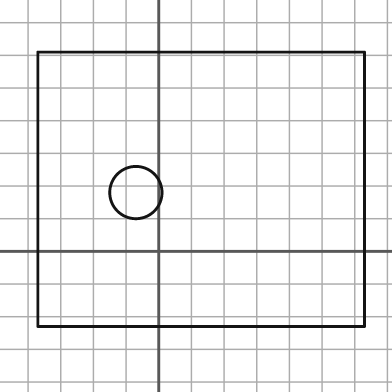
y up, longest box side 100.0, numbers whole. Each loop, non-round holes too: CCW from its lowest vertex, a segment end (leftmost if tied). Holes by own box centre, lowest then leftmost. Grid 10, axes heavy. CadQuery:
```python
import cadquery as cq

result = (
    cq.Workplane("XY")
    .moveTo(-37.0, -23.0)
    .lineTo(63.0, -23.0)
    .lineTo(63.0, 61.0)
    .lineTo(-37.0, 61.0)
    .close()
    .moveTo(-7.0, 18.0)
    .circle(8.0)
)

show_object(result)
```